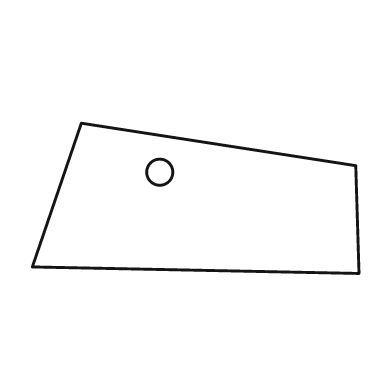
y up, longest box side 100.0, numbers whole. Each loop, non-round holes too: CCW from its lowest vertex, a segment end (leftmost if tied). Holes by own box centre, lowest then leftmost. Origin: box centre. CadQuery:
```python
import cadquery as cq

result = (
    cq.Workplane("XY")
    .moveTo(50.0, -23.0)
    .lineTo(49.0, 10.0)
    .lineTo(-35.0, 23.0)
    .lineTo(-50.0, -21.0)
    .close()
    .moveTo(-11.0, 8.0)
    .circle(4.0)
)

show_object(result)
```